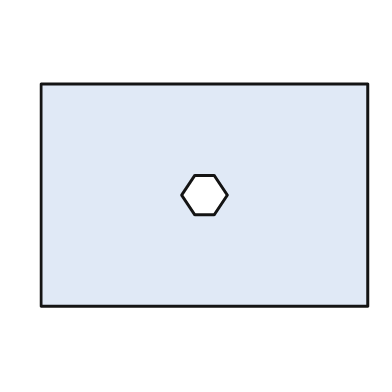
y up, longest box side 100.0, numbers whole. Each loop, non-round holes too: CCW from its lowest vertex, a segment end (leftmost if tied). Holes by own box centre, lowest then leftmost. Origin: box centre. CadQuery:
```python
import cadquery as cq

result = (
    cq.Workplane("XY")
    .moveTo(-50.0, -34.0)
    .lineTo(50.0, -34.0)
    .lineTo(50.0, 34.0)
    .lineTo(-50.0, 34.0)
    .close()
    .moveTo(-3.0, -6.0)
    .lineTo(3.0, -6.0)
    .lineTo(7.0, 0.0)
    .lineTo(3.0, 6.0)
    .lineTo(-3.0, 6.0)
    .lineTo(-7.0, 0.0)
    .close()
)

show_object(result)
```